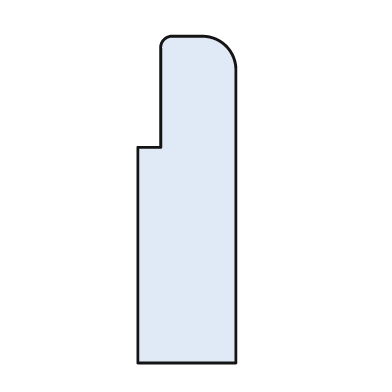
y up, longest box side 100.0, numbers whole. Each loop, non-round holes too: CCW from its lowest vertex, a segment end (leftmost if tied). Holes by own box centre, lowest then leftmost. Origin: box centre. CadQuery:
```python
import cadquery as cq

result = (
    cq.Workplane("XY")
    .moveTo(-15.0, -50.0)
    .lineTo(15.0, -50.0)
    .lineTo(15.0, 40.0)
    .threePointArc((12.0, 47.0), (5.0, 50.0))
    .lineTo(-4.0, 50.0)
    .threePointArc((-7.0, 49.0), (-8.0, 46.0))
    .lineTo(-8.0, 16.0)
    .lineTo(-15.0, 16.0)
    .close()
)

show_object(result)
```